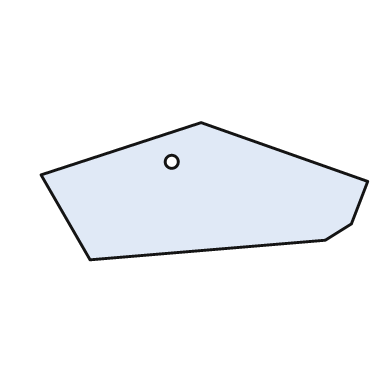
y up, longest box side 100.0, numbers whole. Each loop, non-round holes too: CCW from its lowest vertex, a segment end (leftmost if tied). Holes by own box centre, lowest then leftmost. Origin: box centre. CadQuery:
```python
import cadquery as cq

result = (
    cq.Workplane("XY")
    .moveTo(-35.0, -21.0)
    .lineTo(37.0, -15.0)
    .lineTo(45.0, -10.0)
    .lineTo(50.0, 3.0)
    .lineTo(-1.0, 21.0)
    .lineTo(-50.0, 5.0)
    .close()
    .moveTo(-10.0, 9.0)
    .circle(2.0)
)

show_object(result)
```